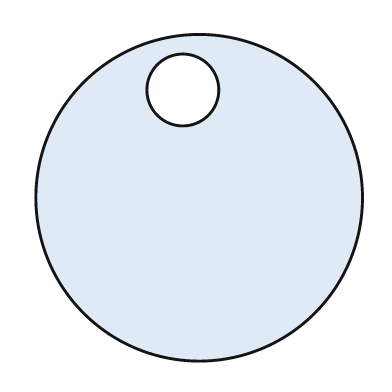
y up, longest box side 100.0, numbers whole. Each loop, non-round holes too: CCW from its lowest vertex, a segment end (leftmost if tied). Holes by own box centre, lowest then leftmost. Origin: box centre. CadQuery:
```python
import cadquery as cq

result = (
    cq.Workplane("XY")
    .moveTo(0.0, 0.0)
    .circle(50.0)
    .moveTo(-5.0, 33.0)
    .circle(11.0)
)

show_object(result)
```